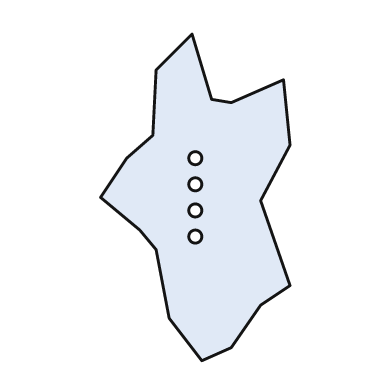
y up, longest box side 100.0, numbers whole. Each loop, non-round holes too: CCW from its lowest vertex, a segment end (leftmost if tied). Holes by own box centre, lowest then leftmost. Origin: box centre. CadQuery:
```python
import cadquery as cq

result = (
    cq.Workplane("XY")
    .moveTo(2.0, -50.0)
    .lineTo(11.0, -46.0)
    .lineTo(20.0, -33.0)
    .lineTo(29.0, -27.0)
    .lineTo(20.0, -1.0)
    .lineTo(29.0, 16.0)
    .lineTo(27.0, 36.0)
    .lineTo(11.0, 29.0)
    .lineTo(5.0, 30.0)
    .lineTo(-1.0, 50.0)
    .lineTo(-12.0, 39.0)
    .lineTo(-13.0, 19.0)
    .lineTo(-21.0, 12.0)
    .lineTo(-29.0, 0.0)
    .lineTo(-17.0, -10.0)
    .lineTo(-12.0, -16.0)
    .lineTo(-8.0, -37.0)
    .close()
    .moveTo(0.0, -12.0)
    .circle(2.0)
    .moveTo(0.0, -4.0)
    .circle(2.0)
    .moveTo(0.0, 4.0)
    .circle(2.0)
    .moveTo(0.0, 12.0)
    .circle(2.0)
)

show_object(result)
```